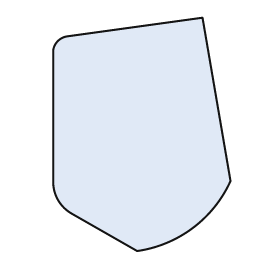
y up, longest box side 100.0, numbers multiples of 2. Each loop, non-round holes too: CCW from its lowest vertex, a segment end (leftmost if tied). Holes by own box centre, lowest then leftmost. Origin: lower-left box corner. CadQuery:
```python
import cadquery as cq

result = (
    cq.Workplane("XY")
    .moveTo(36.0, 0.0)
    .threePointArc((60.0, 10.0), (76.0, 30.0))
    .lineTo(64.0, 100.0)
    .lineTo(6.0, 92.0)
    .threePointArc((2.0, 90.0), (0.0, 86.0))
    .lineTo(0.0, 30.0)
    .threePointArc((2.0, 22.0), (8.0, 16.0))
    .close()
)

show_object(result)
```